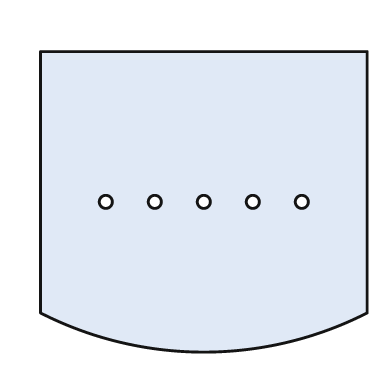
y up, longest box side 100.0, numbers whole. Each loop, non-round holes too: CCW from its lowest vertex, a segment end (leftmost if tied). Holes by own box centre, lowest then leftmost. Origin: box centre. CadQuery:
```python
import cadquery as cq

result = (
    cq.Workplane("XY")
    .moveTo(-50.0, -34.0)
    .threePointArc((0.0, -46.0), (50.0, -34.0))
    .lineTo(50.0, 46.0)
    .lineTo(-50.0, 46.0)
    .close()
    .moveTo(-30.0, 0.0)
    .circle(2.0)
    .moveTo(-15.0, 0.0)
    .circle(2.0)
    .moveTo(0.0, 0.0)
    .circle(2.0)
    .moveTo(15.0, 0.0)
    .circle(2.0)
    .moveTo(30.0, 0.0)
    .circle(2.0)
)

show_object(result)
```